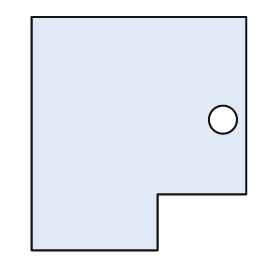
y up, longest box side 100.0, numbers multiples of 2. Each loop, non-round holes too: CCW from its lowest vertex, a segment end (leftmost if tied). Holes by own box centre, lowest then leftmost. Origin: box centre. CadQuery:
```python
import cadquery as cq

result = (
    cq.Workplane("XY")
    .moveTo(-46.0, -50.0)
    .lineTo(8.0, -50.0)
    .lineTo(8.0, -26.0)
    .lineTo(46.0, -26.0)
    .lineTo(46.0, 50.0)
    .lineTo(-46.0, 50.0)
    .close()
    .moveTo(36.0, 6.0)
    .circle(6.0)
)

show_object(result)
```